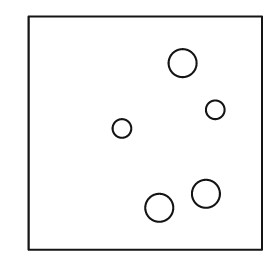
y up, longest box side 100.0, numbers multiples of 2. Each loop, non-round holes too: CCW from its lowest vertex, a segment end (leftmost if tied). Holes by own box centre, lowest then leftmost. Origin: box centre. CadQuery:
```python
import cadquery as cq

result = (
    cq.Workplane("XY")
    .moveTo(-50.0, -50.0)
    .lineTo(50.0, -50.0)
    .lineTo(50.0, 50.0)
    .lineTo(-50.0, 50.0)
    .close()
    .moveTo(6.0, -32.0)
    .circle(6.0)
    .moveTo(26.0, -26.0)
    .circle(6.0)
    .moveTo(-10.0, 2.0)
    .circle(4.0)
    .moveTo(30.0, 10.0)
    .circle(4.0)
    .moveTo(16.0, 30.0)
    .circle(6.0)
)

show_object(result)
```